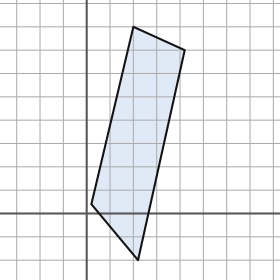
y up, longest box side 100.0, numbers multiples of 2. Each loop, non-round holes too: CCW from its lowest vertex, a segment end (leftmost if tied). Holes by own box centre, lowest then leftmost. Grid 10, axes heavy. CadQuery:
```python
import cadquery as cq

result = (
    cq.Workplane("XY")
    .moveTo(22.0, -20.0)
    .lineTo(42.0, 70.0)
    .lineTo(20.0, 80.0)
    .lineTo(2.0, 4.0)
    .close()
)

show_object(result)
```